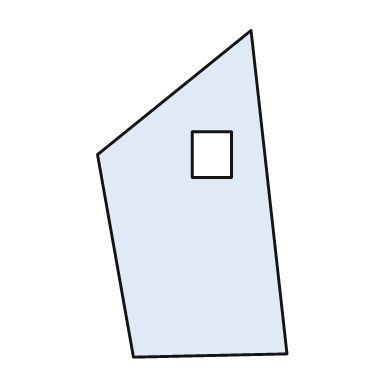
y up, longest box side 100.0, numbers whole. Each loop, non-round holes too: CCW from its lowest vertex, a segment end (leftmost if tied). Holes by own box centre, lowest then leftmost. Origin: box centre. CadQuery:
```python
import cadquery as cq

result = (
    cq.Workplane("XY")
    .moveTo(-18.0, -50.0)
    .lineTo(29.0, -49.0)
    .lineTo(18.0, 50.0)
    .lineTo(-29.0, 12.0)
    .close()
    .moveTo(0.0, 5.0)
    .lineTo(12.0, 5.0)
    .lineTo(12.0, 19.0)
    .lineTo(0.0, 19.0)
    .close()
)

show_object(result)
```